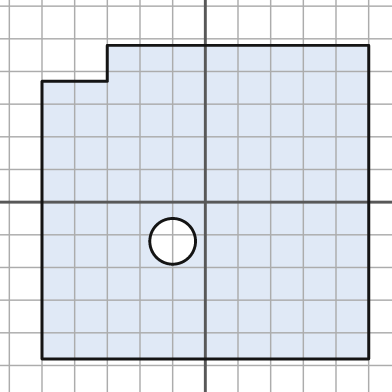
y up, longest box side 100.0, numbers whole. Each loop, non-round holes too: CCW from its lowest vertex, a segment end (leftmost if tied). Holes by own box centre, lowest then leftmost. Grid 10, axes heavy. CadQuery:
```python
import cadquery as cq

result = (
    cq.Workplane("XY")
    .moveTo(-50.0, -48.0)
    .lineTo(50.0, -48.0)
    .lineTo(50.0, 48.0)
    .lineTo(-30.0, 48.0)
    .lineTo(-30.0, 37.0)
    .lineTo(-50.0, 37.0)
    .close()
    .moveTo(-10.0, -12.0)
    .circle(7.0)
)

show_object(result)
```